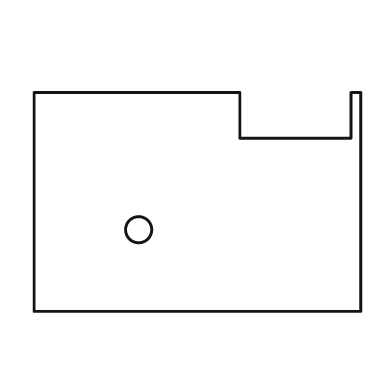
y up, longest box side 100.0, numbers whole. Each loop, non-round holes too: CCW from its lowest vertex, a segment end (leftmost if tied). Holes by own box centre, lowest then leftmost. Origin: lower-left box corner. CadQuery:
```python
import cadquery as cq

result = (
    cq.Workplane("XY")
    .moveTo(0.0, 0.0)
    .lineTo(100.0, 0.0)
    .lineTo(100.0, 67.0)
    .lineTo(97.0, 67.0)
    .lineTo(97.0, 53.0)
    .lineTo(63.0, 53.0)
    .lineTo(63.0, 67.0)
    .lineTo(0.0, 67.0)
    .close()
    .moveTo(32.0, 25.0)
    .circle(4.0)
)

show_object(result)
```